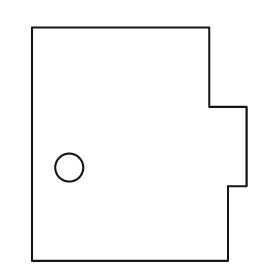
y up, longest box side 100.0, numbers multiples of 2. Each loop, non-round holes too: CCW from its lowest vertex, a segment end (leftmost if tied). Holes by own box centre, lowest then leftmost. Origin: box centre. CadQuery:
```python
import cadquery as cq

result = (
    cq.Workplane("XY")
    .moveTo(-46.0, -50.0)
    .lineTo(38.0, -50.0)
    .lineTo(38.0, -18.0)
    .lineTo(46.0, -18.0)
    .lineTo(46.0, 16.0)
    .lineTo(30.0, 16.0)
    .lineTo(30.0, 50.0)
    .lineTo(-46.0, 50.0)
    .close()
    .moveTo(-30.0, -10.0)
    .circle(6.0)
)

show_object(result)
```